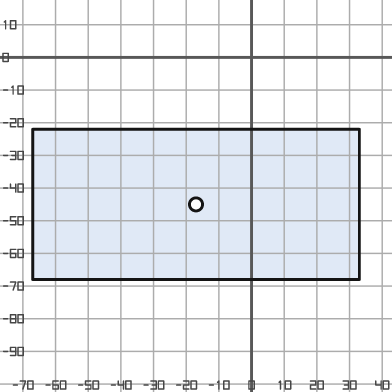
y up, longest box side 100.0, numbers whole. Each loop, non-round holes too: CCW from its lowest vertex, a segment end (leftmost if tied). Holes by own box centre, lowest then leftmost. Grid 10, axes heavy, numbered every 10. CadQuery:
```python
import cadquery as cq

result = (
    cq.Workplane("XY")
    .moveTo(-67.0, -68.0)
    .lineTo(33.0, -68.0)
    .lineTo(33.0, -22.0)
    .lineTo(-67.0, -22.0)
    .close()
    .moveTo(-17.0, -45.0)
    .circle(2.0)
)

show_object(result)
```